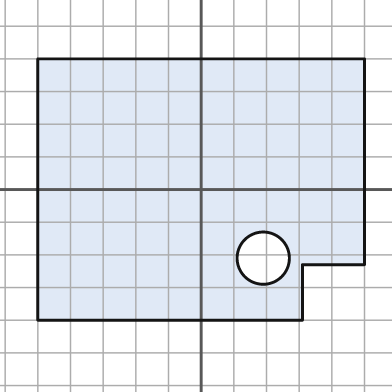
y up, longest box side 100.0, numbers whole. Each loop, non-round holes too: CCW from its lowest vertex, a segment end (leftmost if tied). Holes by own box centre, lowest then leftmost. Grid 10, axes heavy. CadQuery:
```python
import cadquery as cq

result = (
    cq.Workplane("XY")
    .moveTo(-50.0, -40.0)
    .lineTo(31.0, -40.0)
    .lineTo(31.0, -23.0)
    .lineTo(50.0, -23.0)
    .lineTo(50.0, 40.0)
    .lineTo(-50.0, 40.0)
    .close()
    .moveTo(19.0, -21.0)
    .circle(8.0)
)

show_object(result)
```